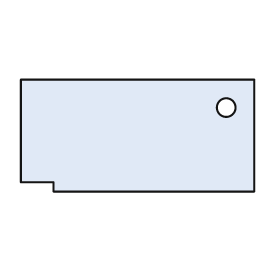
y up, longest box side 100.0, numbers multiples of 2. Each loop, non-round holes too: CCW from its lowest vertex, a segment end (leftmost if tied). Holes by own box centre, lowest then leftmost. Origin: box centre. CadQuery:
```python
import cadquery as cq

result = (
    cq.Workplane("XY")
    .moveTo(-36.0, -24.0)
    .lineTo(50.0, -24.0)
    .lineTo(50.0, 24.0)
    .lineTo(-50.0, 24.0)
    .lineTo(-50.0, -20.0)
    .lineTo(-36.0, -20.0)
    .close()
    .moveTo(38.0, 12.0)
    .circle(4.0)
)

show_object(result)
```